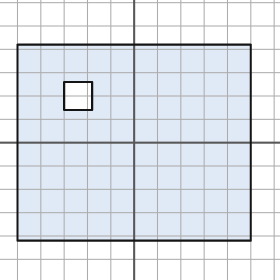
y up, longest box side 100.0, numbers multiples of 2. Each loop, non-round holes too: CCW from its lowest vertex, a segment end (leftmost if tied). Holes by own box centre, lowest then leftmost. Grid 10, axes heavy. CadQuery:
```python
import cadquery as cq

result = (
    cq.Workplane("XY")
    .moveTo(-50.0, -42.0)
    .lineTo(50.0, -42.0)
    .lineTo(50.0, 42.0)
    .lineTo(-50.0, 42.0)
    .close()
    .moveTo(-30.0, 14.0)
    .lineTo(-18.0, 14.0)
    .lineTo(-18.0, 26.0)
    .lineTo(-30.0, 26.0)
    .close()
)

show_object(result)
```